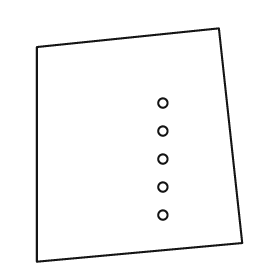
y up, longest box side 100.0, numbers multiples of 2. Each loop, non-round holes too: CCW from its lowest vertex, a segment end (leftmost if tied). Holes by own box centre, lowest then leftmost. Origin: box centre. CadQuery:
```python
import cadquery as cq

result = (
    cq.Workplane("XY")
    .moveTo(-44.0, -50.0)
    .lineTo(44.0, -42.0)
    .lineTo(34.0, 50.0)
    .lineTo(-44.0, 42.0)
    .close()
    .moveTo(10.0, -30.0)
    .circle(2.0)
    .moveTo(10.0, -18.0)
    .circle(2.0)
    .moveTo(10.0, -6.0)
    .circle(2.0)
    .moveTo(10.0, 6.0)
    .circle(2.0)
    .moveTo(10.0, 18.0)
    .circle(2.0)
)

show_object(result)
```